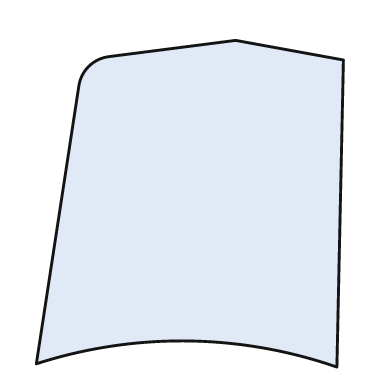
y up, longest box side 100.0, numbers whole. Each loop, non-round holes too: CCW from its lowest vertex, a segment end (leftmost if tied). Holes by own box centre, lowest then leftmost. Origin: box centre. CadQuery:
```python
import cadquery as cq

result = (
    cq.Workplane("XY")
    .moveTo(45.0, -50.0)
    .lineTo(47.0, 44.0)
    .lineTo(14.0, 50.0)
    .lineTo(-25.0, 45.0)
    .threePointArc((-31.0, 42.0), (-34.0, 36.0))
    .lineTo(-47.0, -49.0)
    .threePointArc((-1.0, -42.0), (45.0, -50.0))
    .close()
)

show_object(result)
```